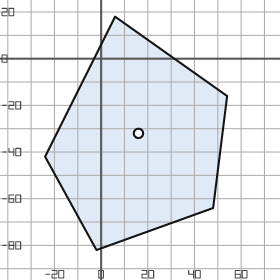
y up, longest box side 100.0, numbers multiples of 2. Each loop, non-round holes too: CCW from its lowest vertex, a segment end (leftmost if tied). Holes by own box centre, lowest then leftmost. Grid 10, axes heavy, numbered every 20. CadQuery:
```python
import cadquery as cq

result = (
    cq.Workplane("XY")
    .moveTo(-2.0, -82.0)
    .lineTo(48.0, -64.0)
    .lineTo(54.0, -16.0)
    .lineTo(6.0, 18.0)
    .lineTo(-24.0, -42.0)
    .close()
    .moveTo(16.0, -32.0)
    .circle(2.0)
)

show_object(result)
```